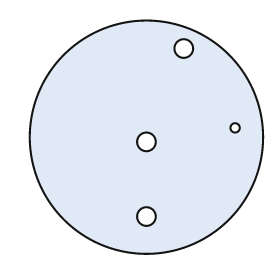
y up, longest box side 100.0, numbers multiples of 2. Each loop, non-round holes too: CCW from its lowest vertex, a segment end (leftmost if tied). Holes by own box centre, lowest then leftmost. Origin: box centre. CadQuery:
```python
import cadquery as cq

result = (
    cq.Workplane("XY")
    .moveTo(0.0, 0.0)
    .circle(50.0)
    .moveTo(0.0, -34.0)
    .circle(4.0)
    .moveTo(0.0, -2.0)
    .circle(4.0)
    .moveTo(38.0, 4.0)
    .circle(2.0)
    .moveTo(16.0, 38.0)
    .circle(4.0)
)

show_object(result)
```